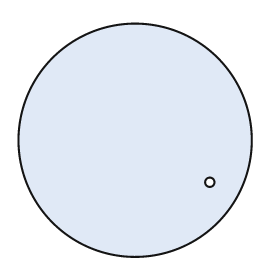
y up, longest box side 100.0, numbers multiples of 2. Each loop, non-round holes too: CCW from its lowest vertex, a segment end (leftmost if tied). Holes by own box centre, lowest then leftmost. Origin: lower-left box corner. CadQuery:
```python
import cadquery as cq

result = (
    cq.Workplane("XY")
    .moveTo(50.0, 50.0)
    .circle(50.0)
    .moveTo(82.0, 32.0)
    .circle(2.0)
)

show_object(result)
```